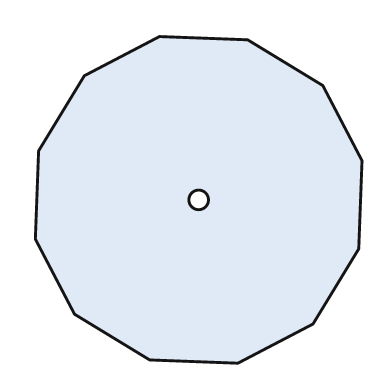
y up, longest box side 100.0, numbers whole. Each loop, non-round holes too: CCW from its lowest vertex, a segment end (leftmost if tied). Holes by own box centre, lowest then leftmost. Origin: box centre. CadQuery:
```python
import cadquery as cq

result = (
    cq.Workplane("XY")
    .moveTo(12.0, -50.0)
    .lineTo(35.0, -38.0)
    .lineTo(49.0, -15.0)
    .lineTo(50.0, 12.0)
    .lineTo(38.0, 35.0)
    .lineTo(15.0, 49.0)
    .lineTo(-12.0, 50.0)
    .lineTo(-35.0, 38.0)
    .lineTo(-49.0, 15.0)
    .lineTo(-50.0, -12.0)
    .lineTo(-38.0, -35.0)
    .lineTo(-15.0, -49.0)
    .close()
    .moveTo(0.0, 0.0)
    .circle(3.0)
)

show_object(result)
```